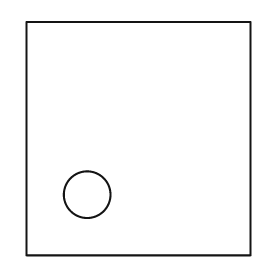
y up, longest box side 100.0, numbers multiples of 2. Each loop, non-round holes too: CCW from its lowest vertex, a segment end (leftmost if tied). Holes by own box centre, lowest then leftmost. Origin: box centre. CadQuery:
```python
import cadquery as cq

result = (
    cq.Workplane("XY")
    .moveTo(-48.0, -50.0)
    .lineTo(48.0, -50.0)
    .lineTo(48.0, 50.0)
    .lineTo(-48.0, 50.0)
    .close()
    .moveTo(-22.0, -24.0)
    .circle(10.0)
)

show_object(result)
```